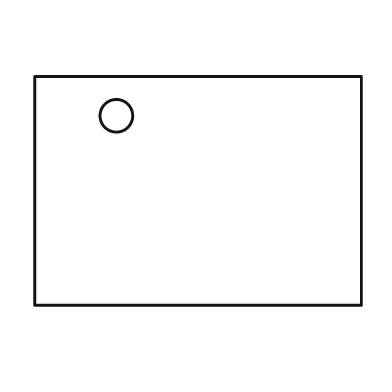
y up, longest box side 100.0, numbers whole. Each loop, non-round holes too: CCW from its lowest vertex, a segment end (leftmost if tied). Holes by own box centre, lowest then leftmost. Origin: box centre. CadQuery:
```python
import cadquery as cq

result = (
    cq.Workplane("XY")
    .moveTo(-50.0, -35.0)
    .lineTo(50.0, -35.0)
    .lineTo(50.0, 35.0)
    .lineTo(-50.0, 35.0)
    .close()
    .moveTo(-25.0, 23.0)
    .circle(5.0)
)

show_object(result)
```